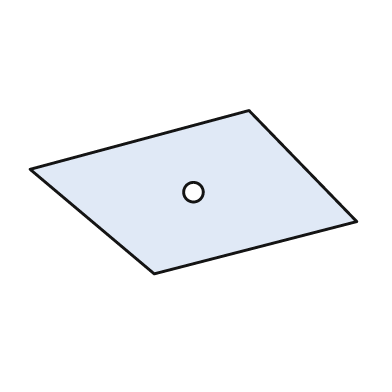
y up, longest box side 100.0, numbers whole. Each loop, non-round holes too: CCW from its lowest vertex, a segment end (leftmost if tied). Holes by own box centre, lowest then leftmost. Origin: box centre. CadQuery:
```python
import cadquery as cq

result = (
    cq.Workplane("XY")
    .moveTo(-12.0, -25.0)
    .lineTo(50.0, -9.0)
    .lineTo(17.0, 25.0)
    .lineTo(-50.0, 7.0)
    .close()
    .moveTo(0.0, 0.0)
    .circle(3.0)
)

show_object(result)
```